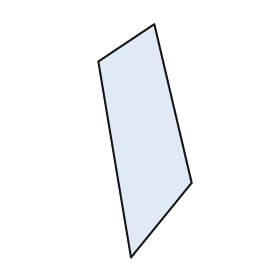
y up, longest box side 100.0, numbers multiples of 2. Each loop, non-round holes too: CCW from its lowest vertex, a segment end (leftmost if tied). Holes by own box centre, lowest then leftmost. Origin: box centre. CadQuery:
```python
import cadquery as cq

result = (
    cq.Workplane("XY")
    .moveTo(-6.0, -50.0)
    .lineTo(20.0, -18.0)
    .lineTo(4.0, 50.0)
    .lineTo(-20.0, 34.0)
    .close()
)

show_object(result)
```